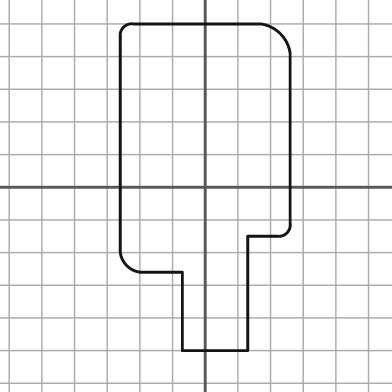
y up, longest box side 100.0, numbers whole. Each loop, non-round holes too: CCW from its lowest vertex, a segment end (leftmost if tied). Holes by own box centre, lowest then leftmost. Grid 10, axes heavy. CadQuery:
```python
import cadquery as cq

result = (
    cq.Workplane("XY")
    .moveTo(-7.0, -50.0)
    .lineTo(13.0, -50.0)
    .lineTo(13.0, -15.0)
    .lineTo(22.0, -15.0)
    .threePointArc((25.0, -14.0), (26.0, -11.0))
    .lineTo(26.0, 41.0)
    .threePointArc((23.0, 47.0), (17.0, 50.0))
    .lineTo(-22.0, 50.0)
    .threePointArc((-25.0, 49.0), (-26.0, 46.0))
    .lineTo(-26.0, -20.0)
    .threePointArc((-24.0, -24.0), (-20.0, -26.0))
    .lineTo(-7.0, -26.0)
    .close()
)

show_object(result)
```